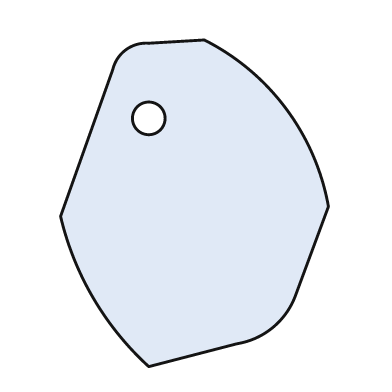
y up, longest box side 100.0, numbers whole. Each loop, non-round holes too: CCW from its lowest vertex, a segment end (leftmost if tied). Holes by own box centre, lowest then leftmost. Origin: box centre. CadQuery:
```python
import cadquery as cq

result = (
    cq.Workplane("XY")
    .moveTo(-14.0, -50.0)
    .lineTo(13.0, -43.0)
    .threePointArc((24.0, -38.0), (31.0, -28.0))
    .lineTo(41.0, -1.0)
    .threePointArc((28.0, 29.0), (3.0, 50.0))
    .lineTo(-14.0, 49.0)
    .threePointArc((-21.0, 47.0), (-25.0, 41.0))
    .lineTo(-41.0, -4.0)
    .threePointArc((-31.0, -29.0), (-14.0, -50.0))
    .close()
    .moveTo(-14.0, 26.0)
    .circle(5.0)
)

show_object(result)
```